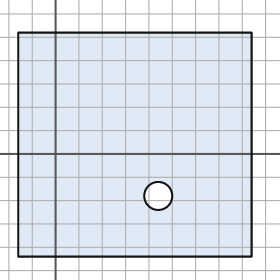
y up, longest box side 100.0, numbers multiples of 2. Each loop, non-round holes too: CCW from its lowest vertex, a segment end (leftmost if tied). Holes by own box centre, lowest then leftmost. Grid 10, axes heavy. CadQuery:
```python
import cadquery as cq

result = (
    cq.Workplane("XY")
    .moveTo(-16.0, -44.0)
    .lineTo(84.0, -44.0)
    .lineTo(84.0, 52.0)
    .lineTo(-16.0, 52.0)
    .close()
    .moveTo(44.0, -18.0)
    .circle(6.0)
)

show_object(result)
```